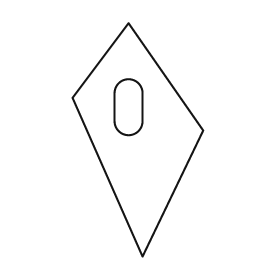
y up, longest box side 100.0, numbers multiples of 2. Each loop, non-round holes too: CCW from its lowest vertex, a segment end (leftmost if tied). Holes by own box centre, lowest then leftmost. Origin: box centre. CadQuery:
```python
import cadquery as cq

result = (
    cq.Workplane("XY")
    .moveTo(2.0, -50.0)
    .lineTo(28.0, 4.0)
    .lineTo(-4.0, 50.0)
    .lineTo(-28.0, 18.0)
    .close()
    .moveTo(-10.0, 8.0)
    .threePointArc((-4.0, 2.0), (2.0, 8.0))
    .lineTo(2.0, 20.0)
    .threePointArc((-4.0, 26.0), (-10.0, 20.0))
    .close()
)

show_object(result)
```